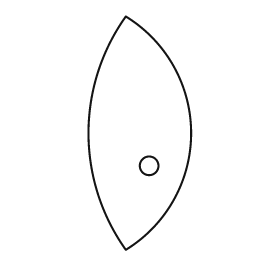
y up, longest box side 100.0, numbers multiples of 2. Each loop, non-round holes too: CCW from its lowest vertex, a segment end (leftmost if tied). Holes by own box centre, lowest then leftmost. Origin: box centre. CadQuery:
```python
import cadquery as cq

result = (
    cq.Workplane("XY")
    .moveTo(-6.0, -50.0)
    .threePointArc((22.0, 0.0), (-6.0, 50.0))
    .threePointArc((-22.0, 0.0), (-6.0, -50.0))
    .close()
    .moveTo(4.0, -14.0)
    .circle(4.0)
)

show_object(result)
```